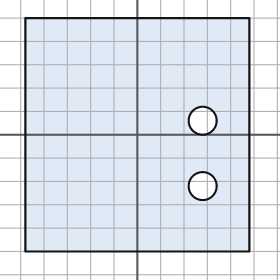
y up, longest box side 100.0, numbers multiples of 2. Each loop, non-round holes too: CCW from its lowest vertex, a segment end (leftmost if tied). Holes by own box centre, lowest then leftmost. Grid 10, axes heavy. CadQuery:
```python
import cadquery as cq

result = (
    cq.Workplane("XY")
    .moveTo(-48.0, -50.0)
    .lineTo(48.0, -50.0)
    .lineTo(48.0, 50.0)
    .lineTo(-48.0, 50.0)
    .close()
    .moveTo(28.0, -22.0)
    .circle(6.0)
    .moveTo(28.0, 6.0)
    .circle(6.0)
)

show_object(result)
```